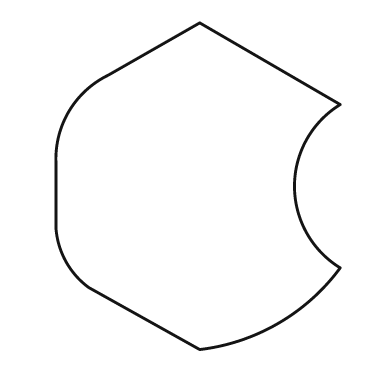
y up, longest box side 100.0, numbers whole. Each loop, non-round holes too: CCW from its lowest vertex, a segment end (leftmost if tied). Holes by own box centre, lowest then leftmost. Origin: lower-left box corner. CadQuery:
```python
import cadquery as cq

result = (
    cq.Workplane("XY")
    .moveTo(44.0, 0.0)
    .threePointArc((68.0, 8.0), (87.0, 25.0))
    .threePointArc((73.0, 50.0), (87.0, 75.0))
    .lineTo(44.0, 100.0)
    .lineTo(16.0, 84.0)
    .threePointArc((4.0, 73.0), (0.0, 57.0))
    .lineTo(0.0, 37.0)
    .threePointArc((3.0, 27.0), (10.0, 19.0))
    .close()
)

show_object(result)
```